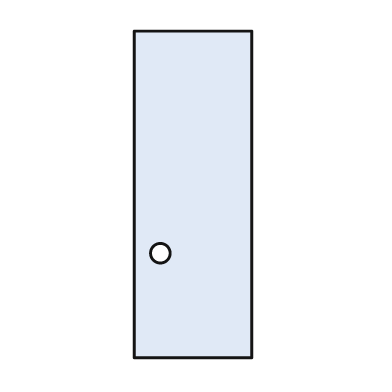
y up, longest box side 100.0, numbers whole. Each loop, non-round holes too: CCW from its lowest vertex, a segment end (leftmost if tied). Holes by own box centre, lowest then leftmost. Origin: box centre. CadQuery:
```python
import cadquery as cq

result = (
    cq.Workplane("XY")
    .moveTo(-18.0, -50.0)
    .lineTo(18.0, -50.0)
    .lineTo(18.0, 50.0)
    .lineTo(-18.0, 50.0)
    .close()
    .moveTo(-10.0, -18.0)
    .circle(3.0)
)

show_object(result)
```